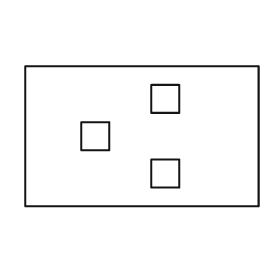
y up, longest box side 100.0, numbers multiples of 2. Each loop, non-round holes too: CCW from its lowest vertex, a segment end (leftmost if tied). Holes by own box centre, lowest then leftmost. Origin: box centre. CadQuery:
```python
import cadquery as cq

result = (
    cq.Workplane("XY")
    .moveTo(-50.0, -30.0)
    .lineTo(50.0, -30.0)
    .lineTo(50.0, 30.0)
    .lineTo(-50.0, 30.0)
    .close()
    .moveTo(4.0, -22.0)
    .lineTo(16.0, -22.0)
    .lineTo(16.0, -10.0)
    .lineTo(4.0, -10.0)
    .close()
    .moveTo(-26.0, -6.0)
    .lineTo(-14.0, -6.0)
    .lineTo(-14.0, 6.0)
    .lineTo(-26.0, 6.0)
    .close()
    .moveTo(4.0, 10.0)
    .lineTo(16.0, 10.0)
    .lineTo(16.0, 22.0)
    .lineTo(4.0, 22.0)
    .close()
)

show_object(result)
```